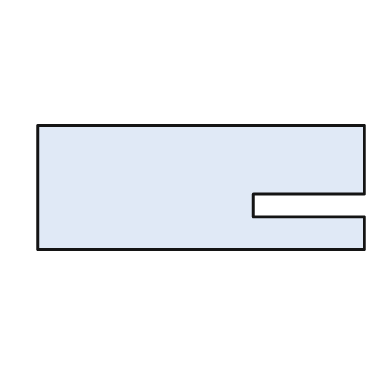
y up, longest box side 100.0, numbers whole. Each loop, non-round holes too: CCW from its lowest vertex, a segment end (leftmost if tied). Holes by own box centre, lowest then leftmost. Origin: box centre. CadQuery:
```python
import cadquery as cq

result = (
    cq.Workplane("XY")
    .moveTo(-50.0, -19.0)
    .lineTo(50.0, -19.0)
    .lineTo(50.0, -9.0)
    .lineTo(16.0, -9.0)
    .lineTo(16.0, -2.0)
    .lineTo(50.0, -2.0)
    .lineTo(50.0, 19.0)
    .lineTo(-50.0, 19.0)
    .close()
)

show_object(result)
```